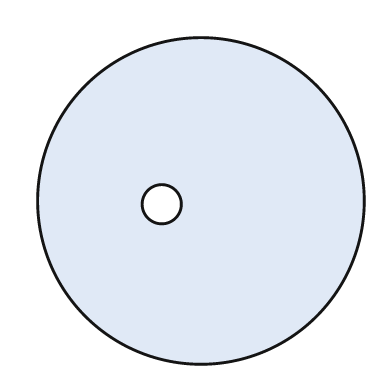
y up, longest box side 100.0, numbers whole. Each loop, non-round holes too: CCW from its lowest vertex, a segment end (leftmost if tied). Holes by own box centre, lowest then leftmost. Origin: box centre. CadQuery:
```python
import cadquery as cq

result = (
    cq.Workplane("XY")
    .moveTo(0.0, 0.0)
    .circle(50.0)
    .moveTo(-12.0, -1.0)
    .circle(6.0)
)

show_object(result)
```